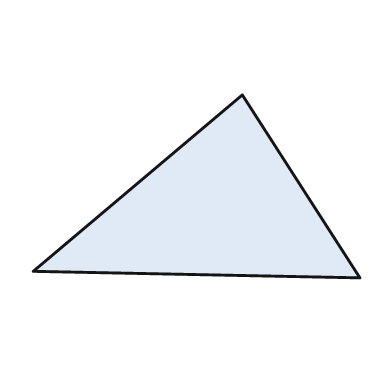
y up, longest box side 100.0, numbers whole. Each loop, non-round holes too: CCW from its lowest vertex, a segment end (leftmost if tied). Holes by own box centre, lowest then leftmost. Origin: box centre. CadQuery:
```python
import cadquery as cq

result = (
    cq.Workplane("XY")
    .moveTo(50.0, -28.0)
    .lineTo(14.0, 28.0)
    .lineTo(-50.0, -26.0)
    .close()
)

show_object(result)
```